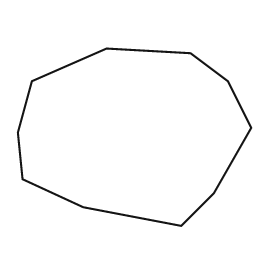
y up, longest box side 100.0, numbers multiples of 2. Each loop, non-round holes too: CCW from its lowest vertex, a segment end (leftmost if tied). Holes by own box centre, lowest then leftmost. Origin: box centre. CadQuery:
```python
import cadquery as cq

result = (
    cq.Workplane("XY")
    .moveTo(20.0, -38.0)
    .lineTo(34.0, -24.0)
    .lineTo(50.0, 4.0)
    .lineTo(40.0, 24.0)
    .lineTo(24.0, 36.0)
    .lineTo(-12.0, 38.0)
    .lineTo(-44.0, 24.0)
    .lineTo(-50.0, 2.0)
    .lineTo(-48.0, -18.0)
    .lineTo(-22.0, -30.0)
    .close()
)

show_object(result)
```